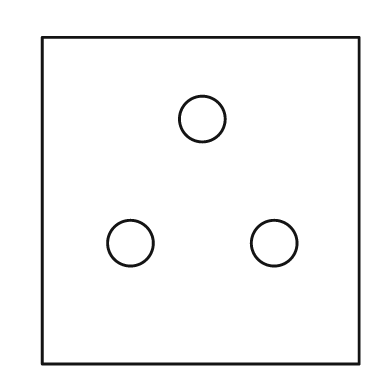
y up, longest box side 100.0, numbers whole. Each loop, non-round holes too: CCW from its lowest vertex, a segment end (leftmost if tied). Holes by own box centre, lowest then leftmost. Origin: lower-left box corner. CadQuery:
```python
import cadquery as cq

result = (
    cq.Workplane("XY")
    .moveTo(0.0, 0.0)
    .lineTo(97.0, 0.0)
    .lineTo(97.0, 100.0)
    .lineTo(0.0, 100.0)
    .close()
    .moveTo(27.0, 37.0)
    .circle(7.0)
    .moveTo(71.0, 37.0)
    .circle(7.0)
    .moveTo(49.0, 75.0)
    .circle(7.0)
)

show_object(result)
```